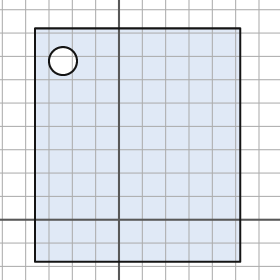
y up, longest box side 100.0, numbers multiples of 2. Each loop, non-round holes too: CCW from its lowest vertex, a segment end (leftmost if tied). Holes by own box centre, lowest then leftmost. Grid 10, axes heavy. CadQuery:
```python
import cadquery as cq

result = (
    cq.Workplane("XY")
    .moveTo(-36.0, -18.0)
    .lineTo(52.0, -18.0)
    .lineTo(52.0, 82.0)
    .lineTo(-36.0, 82.0)
    .close()
    .moveTo(-24.0, 68.0)
    .circle(6.0)
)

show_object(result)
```